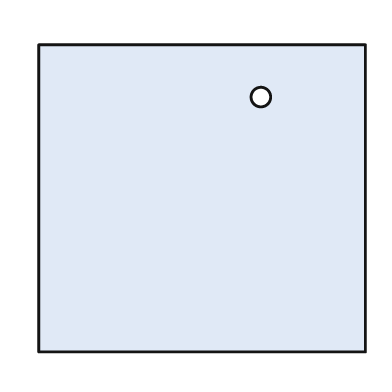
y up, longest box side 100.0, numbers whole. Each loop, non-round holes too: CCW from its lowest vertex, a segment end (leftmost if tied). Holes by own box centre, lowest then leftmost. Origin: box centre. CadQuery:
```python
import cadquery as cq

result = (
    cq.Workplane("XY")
    .moveTo(-50.0, -47.0)
    .lineTo(50.0, -47.0)
    .lineTo(50.0, 47.0)
    .lineTo(-50.0, 47.0)
    .close()
    .moveTo(18.0, 31.0)
    .circle(3.0)
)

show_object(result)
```